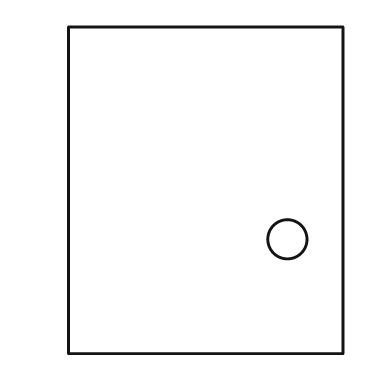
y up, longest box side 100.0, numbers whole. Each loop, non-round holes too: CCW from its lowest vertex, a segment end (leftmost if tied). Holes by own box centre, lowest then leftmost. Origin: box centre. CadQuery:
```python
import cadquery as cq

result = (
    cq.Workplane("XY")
    .moveTo(-42.0, -50.0)
    .lineTo(42.0, -50.0)
    .lineTo(42.0, 50.0)
    .lineTo(-42.0, 50.0)
    .close()
    .moveTo(25.0, -15.0)
    .circle(6.0)
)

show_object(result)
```